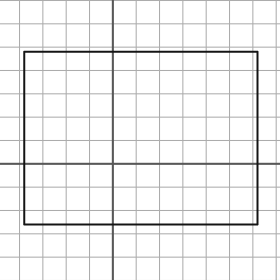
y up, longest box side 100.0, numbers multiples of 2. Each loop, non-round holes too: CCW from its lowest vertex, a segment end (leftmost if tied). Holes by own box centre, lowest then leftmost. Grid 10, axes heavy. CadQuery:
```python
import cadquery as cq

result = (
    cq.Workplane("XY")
    .moveTo(-38.0, -26.0)
    .lineTo(62.0, -26.0)
    .lineTo(62.0, 48.0)
    .lineTo(-38.0, 48.0)
    .close()
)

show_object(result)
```